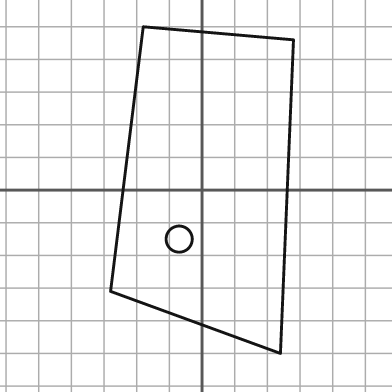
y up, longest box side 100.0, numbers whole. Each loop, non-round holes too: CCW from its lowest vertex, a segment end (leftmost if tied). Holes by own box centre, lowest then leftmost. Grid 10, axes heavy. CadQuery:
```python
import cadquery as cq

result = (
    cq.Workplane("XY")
    .moveTo(24.0, -50.0)
    .lineTo(28.0, 46.0)
    .lineTo(-18.0, 50.0)
    .lineTo(-28.0, -31.0)
    .close()
    .moveTo(-7.0, -15.0)
    .circle(4.0)
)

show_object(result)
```